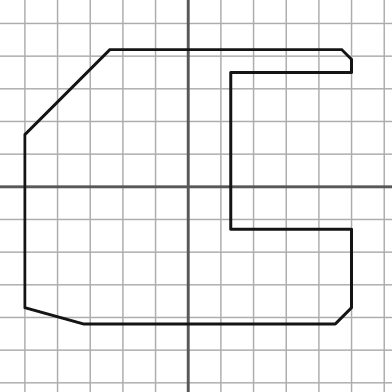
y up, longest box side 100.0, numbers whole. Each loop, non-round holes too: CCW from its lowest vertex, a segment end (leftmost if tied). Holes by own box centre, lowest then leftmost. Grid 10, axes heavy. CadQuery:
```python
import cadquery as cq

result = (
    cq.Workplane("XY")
    .moveTo(-32.0, -42.0)
    .lineTo(45.0, -42.0)
    .lineTo(50.0, -37.0)
    .lineTo(50.0, -13.0)
    .lineTo(13.0, -13.0)
    .lineTo(13.0, 35.0)
    .lineTo(50.0, 35.0)
    .lineTo(50.0, 39.0)
    .lineTo(47.0, 42.0)
    .lineTo(-24.0, 42.0)
    .lineTo(-50.0, 16.0)
    .lineTo(-50.0, -37.0)
    .close()
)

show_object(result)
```